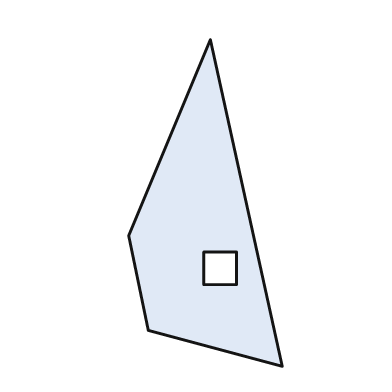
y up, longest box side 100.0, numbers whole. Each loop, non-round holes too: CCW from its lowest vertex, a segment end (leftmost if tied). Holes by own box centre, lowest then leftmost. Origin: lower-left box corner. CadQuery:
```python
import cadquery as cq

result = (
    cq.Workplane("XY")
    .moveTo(47.0, 0.0)
    .lineTo(25.0, 100.0)
    .lineTo(0.0, 40.0)
    .lineTo(6.0, 11.0)
    .close()
    .moveTo(23.0, 25.0)
    .lineTo(33.0, 25.0)
    .lineTo(33.0, 35.0)
    .lineTo(23.0, 35.0)
    .close()
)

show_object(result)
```